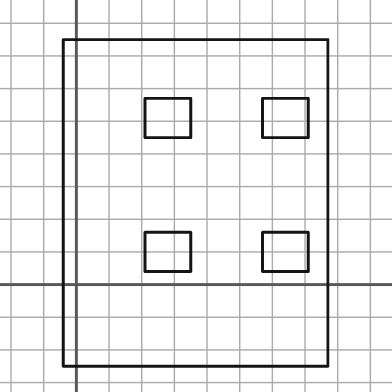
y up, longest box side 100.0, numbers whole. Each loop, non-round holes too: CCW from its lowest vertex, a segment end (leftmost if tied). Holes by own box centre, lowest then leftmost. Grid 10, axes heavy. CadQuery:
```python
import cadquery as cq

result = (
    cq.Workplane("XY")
    .moveTo(-4.0, -25.0)
    .lineTo(77.0, -25.0)
    .lineTo(77.0, 75.0)
    .lineTo(-4.0, 75.0)
    .close()
    .moveTo(21.0, 4.0)
    .lineTo(35.0, 4.0)
    .lineTo(35.0, 16.0)
    .lineTo(21.0, 16.0)
    .close()
    .moveTo(57.0, 4.0)
    .lineTo(71.0, 4.0)
    .lineTo(71.0, 16.0)
    .lineTo(57.0, 16.0)
    .close()
    .moveTo(21.0, 45.0)
    .lineTo(35.0, 45.0)
    .lineTo(35.0, 57.0)
    .lineTo(21.0, 57.0)
    .close()
    .moveTo(57.0, 45.0)
    .lineTo(71.0, 45.0)
    .lineTo(71.0, 57.0)
    .lineTo(57.0, 57.0)
    .close()
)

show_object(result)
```